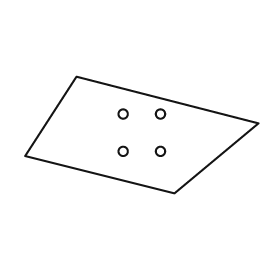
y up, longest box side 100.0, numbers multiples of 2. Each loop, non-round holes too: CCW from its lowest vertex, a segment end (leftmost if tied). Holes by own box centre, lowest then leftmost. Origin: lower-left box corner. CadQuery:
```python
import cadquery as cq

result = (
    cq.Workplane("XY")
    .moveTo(64.0, 0.0)
    .lineTo(100.0, 30.0)
    .lineTo(22.0, 50.0)
    .lineTo(0.0, 16.0)
    .close()
    .moveTo(42.0, 18.0)
    .circle(2.0)
    .moveTo(58.0, 18.0)
    .circle(2.0)
    .moveTo(42.0, 34.0)
    .circle(2.0)
    .moveTo(58.0, 34.0)
    .circle(2.0)
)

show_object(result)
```